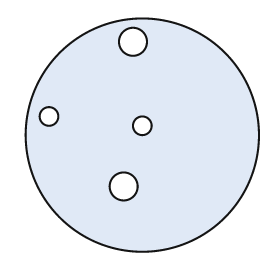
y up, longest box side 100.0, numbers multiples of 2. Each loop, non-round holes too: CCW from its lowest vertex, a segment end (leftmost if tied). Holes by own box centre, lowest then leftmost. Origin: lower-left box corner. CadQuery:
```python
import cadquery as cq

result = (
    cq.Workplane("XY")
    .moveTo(50.0, 50.0)
    .circle(50.0)
    .moveTo(42.0, 28.0)
    .circle(6.0)
    .moveTo(50.0, 54.0)
    .circle(4.0)
    .moveTo(10.0, 58.0)
    .circle(4.0)
    .moveTo(46.0, 90.0)
    .circle(6.0)
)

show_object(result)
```